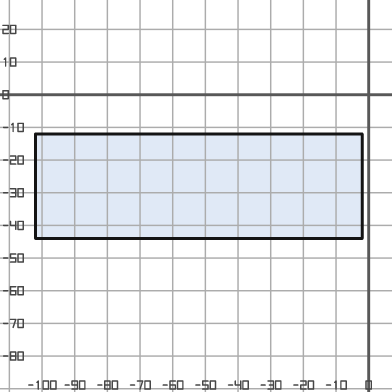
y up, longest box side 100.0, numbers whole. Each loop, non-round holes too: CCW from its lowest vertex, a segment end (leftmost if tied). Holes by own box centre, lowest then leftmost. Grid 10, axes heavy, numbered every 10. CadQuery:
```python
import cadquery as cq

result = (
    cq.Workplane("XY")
    .moveTo(-102.0, -44.0)
    .lineTo(-2.0, -44.0)
    .lineTo(-2.0, -12.0)
    .lineTo(-102.0, -12.0)
    .close()
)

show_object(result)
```